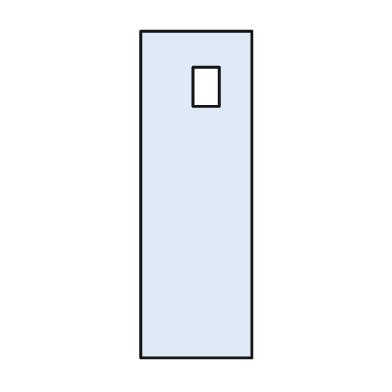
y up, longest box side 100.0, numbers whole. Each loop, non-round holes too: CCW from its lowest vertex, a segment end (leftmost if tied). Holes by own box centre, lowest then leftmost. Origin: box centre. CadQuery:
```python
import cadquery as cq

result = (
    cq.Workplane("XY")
    .moveTo(-17.0, -50.0)
    .lineTo(17.0, -50.0)
    .lineTo(17.0, 50.0)
    .lineTo(-17.0, 50.0)
    .close()
    .moveTo(-1.0, 27.0)
    .lineTo(7.0, 27.0)
    .lineTo(7.0, 39.0)
    .lineTo(-1.0, 39.0)
    .close()
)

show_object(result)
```